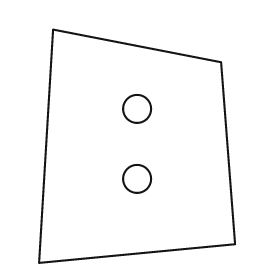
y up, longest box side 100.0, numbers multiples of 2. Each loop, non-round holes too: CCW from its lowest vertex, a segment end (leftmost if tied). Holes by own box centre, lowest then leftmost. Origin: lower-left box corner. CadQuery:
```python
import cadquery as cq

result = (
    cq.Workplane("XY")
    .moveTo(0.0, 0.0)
    .lineTo(84.0, 8.0)
    .lineTo(78.0, 86.0)
    .lineTo(6.0, 100.0)
    .close()
    .moveTo(42.0, 36.0)
    .circle(6.0)
    .moveTo(42.0, 66.0)
    .circle(6.0)
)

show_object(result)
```